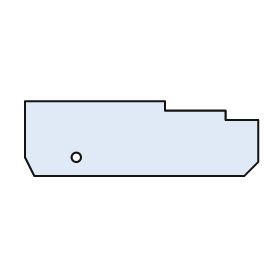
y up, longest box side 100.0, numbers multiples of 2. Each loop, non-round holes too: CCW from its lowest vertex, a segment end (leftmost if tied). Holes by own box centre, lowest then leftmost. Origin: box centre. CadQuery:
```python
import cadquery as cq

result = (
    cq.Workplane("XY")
    .moveTo(-46.0, -16.0)
    .lineTo(44.0, -16.0)
    .lineTo(50.0, -10.0)
    .lineTo(50.0, 8.0)
    .lineTo(36.0, 8.0)
    .lineTo(36.0, 12.0)
    .lineTo(10.0, 12.0)
    .lineTo(10.0, 16.0)
    .lineTo(-50.0, 16.0)
    .lineTo(-50.0, -8.0)
    .close()
    .moveTo(-28.0, -8.0)
    .circle(2.0)
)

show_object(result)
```